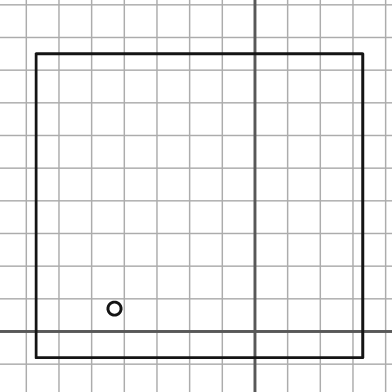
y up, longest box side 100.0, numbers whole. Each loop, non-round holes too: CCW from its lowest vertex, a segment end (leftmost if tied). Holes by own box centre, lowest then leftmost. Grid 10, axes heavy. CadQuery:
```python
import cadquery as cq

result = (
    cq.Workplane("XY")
    .moveTo(-67.0, -8.0)
    .lineTo(33.0, -8.0)
    .lineTo(33.0, 85.0)
    .lineTo(-67.0, 85.0)
    .close()
    .moveTo(-43.0, 7.0)
    .circle(2.0)
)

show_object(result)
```